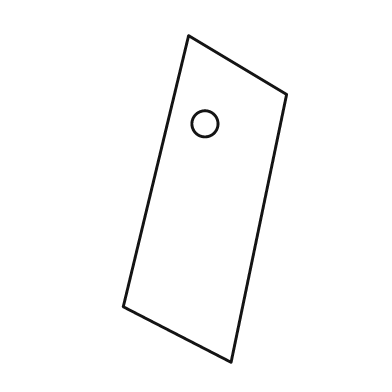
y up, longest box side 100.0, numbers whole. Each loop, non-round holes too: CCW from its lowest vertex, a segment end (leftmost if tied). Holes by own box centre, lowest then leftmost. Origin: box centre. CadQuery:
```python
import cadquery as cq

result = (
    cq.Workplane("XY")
    .moveTo(8.0, -50.0)
    .lineTo(25.0, 32.0)
    .lineTo(-5.0, 50.0)
    .lineTo(-25.0, -33.0)
    .close()
    .moveTo(0.0, 23.0)
    .circle(4.0)
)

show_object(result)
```